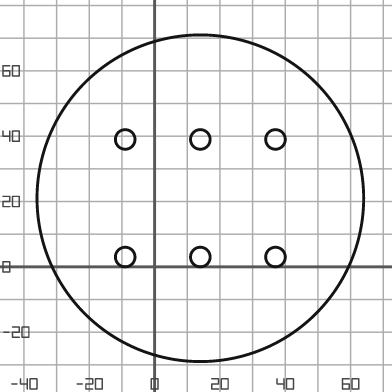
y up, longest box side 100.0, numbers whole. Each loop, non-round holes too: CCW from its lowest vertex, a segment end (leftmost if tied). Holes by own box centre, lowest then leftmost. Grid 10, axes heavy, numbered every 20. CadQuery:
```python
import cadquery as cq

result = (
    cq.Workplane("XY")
    .moveTo(14.0, 21.0)
    .circle(50.0)
    .moveTo(-9.0, 3.0)
    .circle(3.0)
    .moveTo(14.0, 3.0)
    .circle(3.0)
    .moveTo(37.0, 3.0)
    .circle(3.0)
    .moveTo(-9.0, 39.0)
    .circle(3.0)
    .moveTo(14.0, 39.0)
    .circle(3.0)
    .moveTo(37.0, 39.0)
    .circle(3.0)
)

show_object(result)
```